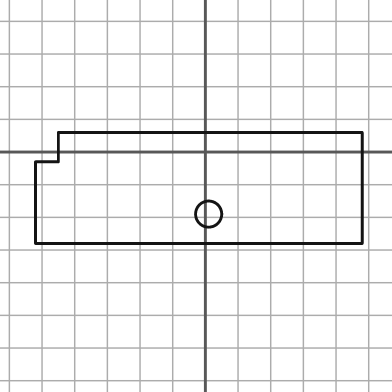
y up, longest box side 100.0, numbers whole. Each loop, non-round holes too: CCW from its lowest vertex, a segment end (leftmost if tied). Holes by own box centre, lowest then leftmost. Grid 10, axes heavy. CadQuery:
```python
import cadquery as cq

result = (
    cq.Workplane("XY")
    .moveTo(-52.0, -28.0)
    .lineTo(48.0, -28.0)
    .lineTo(48.0, 6.0)
    .lineTo(-45.0, 6.0)
    .lineTo(-45.0, -3.0)
    .lineTo(-52.0, -3.0)
    .close()
    .moveTo(1.0, -19.0)
    .circle(4.0)
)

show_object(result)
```